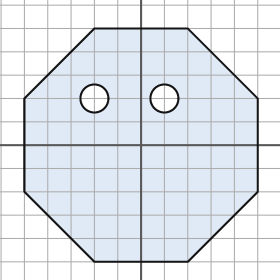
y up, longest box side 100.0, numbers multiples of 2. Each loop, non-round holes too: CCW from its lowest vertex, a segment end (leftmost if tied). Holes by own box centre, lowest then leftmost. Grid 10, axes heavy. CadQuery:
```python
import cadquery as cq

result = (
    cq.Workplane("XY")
    .moveTo(-20.0, -50.0)
    .lineTo(20.0, -50.0)
    .lineTo(50.0, -20.0)
    .lineTo(50.0, 20.0)
    .lineTo(20.0, 50.0)
    .lineTo(-20.0, 50.0)
    .lineTo(-50.0, 20.0)
    .lineTo(-50.0, -20.0)
    .close()
    .moveTo(-20.0, 20.0)
    .circle(6.0)
    .moveTo(10.0, 20.0)
    .circle(6.0)
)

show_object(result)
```